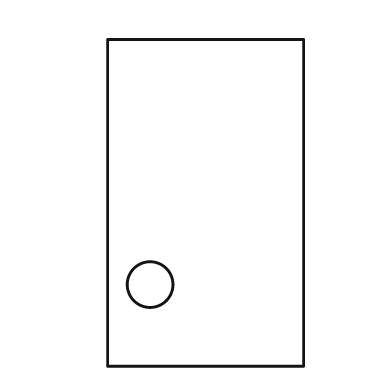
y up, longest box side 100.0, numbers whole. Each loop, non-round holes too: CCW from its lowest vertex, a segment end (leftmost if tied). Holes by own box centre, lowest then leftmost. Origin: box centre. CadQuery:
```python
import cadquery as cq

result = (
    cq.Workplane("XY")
    .moveTo(-30.0, -50.0)
    .lineTo(30.0, -50.0)
    .lineTo(30.0, 50.0)
    .lineTo(-30.0, 50.0)
    .close()
    .moveTo(-17.0, -25.0)
    .circle(7.0)
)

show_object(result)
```